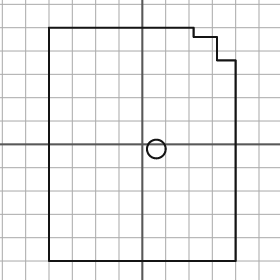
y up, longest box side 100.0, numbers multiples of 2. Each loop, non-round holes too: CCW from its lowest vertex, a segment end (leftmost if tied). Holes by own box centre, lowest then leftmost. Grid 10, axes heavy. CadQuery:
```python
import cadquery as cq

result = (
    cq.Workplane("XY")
    .moveTo(-40.0, -50.0)
    .lineTo(40.0, -50.0)
    .lineTo(40.0, 36.0)
    .lineTo(32.0, 36.0)
    .lineTo(32.0, 46.0)
    .lineTo(22.0, 46.0)
    .lineTo(22.0, 50.0)
    .lineTo(-40.0, 50.0)
    .close()
    .moveTo(6.0, -2.0)
    .circle(4.0)
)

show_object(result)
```